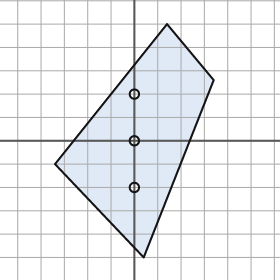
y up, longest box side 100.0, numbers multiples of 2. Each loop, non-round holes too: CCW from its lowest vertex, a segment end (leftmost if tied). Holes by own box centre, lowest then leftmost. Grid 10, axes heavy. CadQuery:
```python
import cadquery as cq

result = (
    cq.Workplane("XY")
    .moveTo(4.0, -50.0)
    .lineTo(34.0, 26.0)
    .lineTo(14.0, 50.0)
    .lineTo(-34.0, -10.0)
    .close()
    .moveTo(0.0, -20.0)
    .circle(2.0)
    .moveTo(0.0, 0.0)
    .circle(2.0)
    .moveTo(0.0, 20.0)
    .circle(2.0)
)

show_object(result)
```